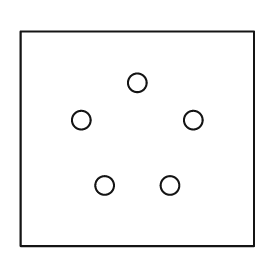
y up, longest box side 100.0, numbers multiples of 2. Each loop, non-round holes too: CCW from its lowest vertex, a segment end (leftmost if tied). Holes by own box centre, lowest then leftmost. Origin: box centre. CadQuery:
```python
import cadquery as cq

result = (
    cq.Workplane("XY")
    .moveTo(-50.0, -46.0)
    .lineTo(50.0, -46.0)
    .lineTo(50.0, 46.0)
    .lineTo(-50.0, 46.0)
    .close()
    .moveTo(-14.0, -20.0)
    .circle(4.0)
    .moveTo(14.0, -20.0)
    .circle(4.0)
    .moveTo(-24.0, 8.0)
    .circle(4.0)
    .moveTo(24.0, 8.0)
    .circle(4.0)
    .moveTo(0.0, 24.0)
    .circle(4.0)
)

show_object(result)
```